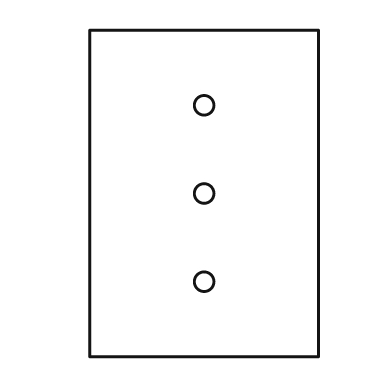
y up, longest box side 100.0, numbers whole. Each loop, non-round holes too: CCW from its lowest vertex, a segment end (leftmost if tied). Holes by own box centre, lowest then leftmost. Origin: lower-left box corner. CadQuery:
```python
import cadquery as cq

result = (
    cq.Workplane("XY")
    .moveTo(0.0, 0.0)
    .lineTo(70.0, 0.0)
    .lineTo(70.0, 100.0)
    .lineTo(0.0, 100.0)
    .close()
    .moveTo(35.0, 23.0)
    .circle(3.0)
    .moveTo(35.0, 50.0)
    .circle(3.0)
    .moveTo(35.0, 77.0)
    .circle(3.0)
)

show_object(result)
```